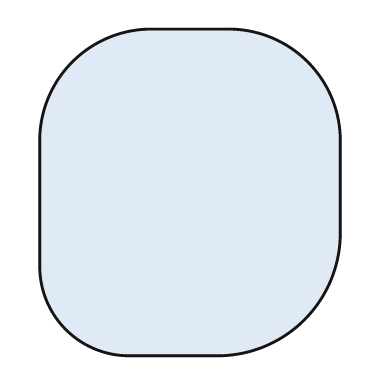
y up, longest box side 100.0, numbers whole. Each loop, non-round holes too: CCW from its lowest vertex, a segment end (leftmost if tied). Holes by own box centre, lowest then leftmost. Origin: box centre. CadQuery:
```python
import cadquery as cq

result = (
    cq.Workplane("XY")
    .moveTo(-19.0, -50.0)
    .lineTo(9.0, -50.0)
    .threePointArc((35.0, -39.0), (46.0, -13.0))
    .lineTo(46.0, 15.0)
    .threePointArc((36.0, 40.0), (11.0, 50.0))
    .lineTo(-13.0, 50.0)
    .threePointArc((-36.0, 40.0), (-46.0, 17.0))
    .lineTo(-46.0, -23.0)
    .threePointArc((-38.0, -42.0), (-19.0, -50.0))
    .close()
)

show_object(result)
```